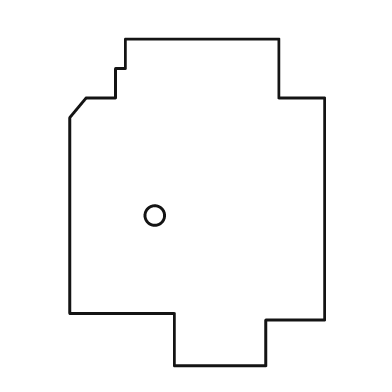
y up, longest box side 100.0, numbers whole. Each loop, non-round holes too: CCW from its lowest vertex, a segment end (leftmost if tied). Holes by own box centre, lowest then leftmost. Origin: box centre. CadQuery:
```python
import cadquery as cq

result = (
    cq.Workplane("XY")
    .moveTo(-7.0, -50.0)
    .lineTo(21.0, -50.0)
    .lineTo(21.0, -36.0)
    .lineTo(39.0, -36.0)
    .lineTo(39.0, 32.0)
    .lineTo(25.0, 32.0)
    .lineTo(25.0, 50.0)
    .lineTo(-22.0, 50.0)
    .lineTo(-22.0, 41.0)
    .lineTo(-25.0, 41.0)
    .lineTo(-25.0, 32.0)
    .lineTo(-34.0, 32.0)
    .lineTo(-39.0, 26.0)
    .lineTo(-39.0, -34.0)
    .lineTo(-7.0, -34.0)
    .close()
    .moveTo(-13.0, -4.0)
    .circle(3.0)
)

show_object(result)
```